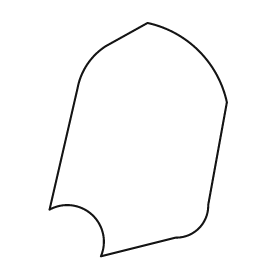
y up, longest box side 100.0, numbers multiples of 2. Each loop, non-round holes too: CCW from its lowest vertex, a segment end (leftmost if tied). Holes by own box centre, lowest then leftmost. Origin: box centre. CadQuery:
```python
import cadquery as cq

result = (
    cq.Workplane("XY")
    .moveTo(-16.0, -50.0)
    .lineTo(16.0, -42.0)
    .threePointArc((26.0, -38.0), (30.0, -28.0))
    .lineTo(38.0, 16.0)
    .threePointArc((26.0, 38.0), (4.0, 50.0))
    .lineTo(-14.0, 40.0)
    .threePointArc((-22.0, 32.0), (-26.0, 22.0))
    .lineTo(-38.0, -30.0)
    .threePointArc((-20.0, -32.0), (-16.0, -50.0))
    .close()
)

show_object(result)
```